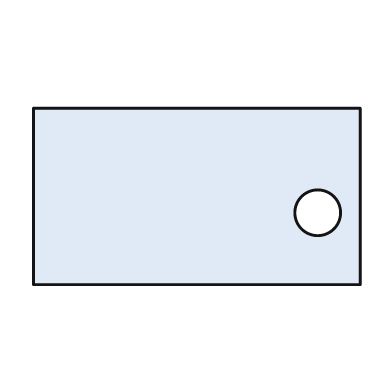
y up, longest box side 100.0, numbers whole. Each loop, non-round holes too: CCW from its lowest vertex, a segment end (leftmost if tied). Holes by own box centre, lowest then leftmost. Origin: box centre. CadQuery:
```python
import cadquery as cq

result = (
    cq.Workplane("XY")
    .moveTo(-50.0, -27.0)
    .lineTo(50.0, -27.0)
    .lineTo(50.0, 27.0)
    .lineTo(-50.0, 27.0)
    .close()
    .moveTo(37.0, -5.0)
    .circle(7.0)
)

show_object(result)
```